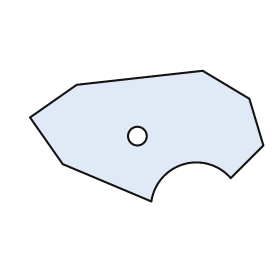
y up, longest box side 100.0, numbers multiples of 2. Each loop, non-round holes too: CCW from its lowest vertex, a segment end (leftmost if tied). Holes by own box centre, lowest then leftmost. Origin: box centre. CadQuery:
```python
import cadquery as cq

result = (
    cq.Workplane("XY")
    .moveTo(2.0, -28.0)
    .threePointArc((16.0, -12.0), (36.0, -18.0))
    .lineTo(50.0, -4.0)
    .lineTo(44.0, 16.0)
    .lineTo(24.0, 28.0)
    .lineTo(-30.0, 22.0)
    .lineTo(-50.0, 8.0)
    .lineTo(-36.0, -12.0)
    .close()
    .moveTo(-4.0, 0.0)
    .circle(4.0)
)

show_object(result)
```